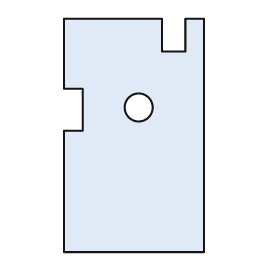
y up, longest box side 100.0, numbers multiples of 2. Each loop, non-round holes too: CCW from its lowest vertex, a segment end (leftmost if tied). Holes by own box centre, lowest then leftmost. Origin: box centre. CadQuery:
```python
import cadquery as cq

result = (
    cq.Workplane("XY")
    .moveTo(-30.0, -50.0)
    .lineTo(30.0, -50.0)
    .lineTo(30.0, 50.0)
    .lineTo(22.0, 50.0)
    .lineTo(22.0, 36.0)
    .lineTo(12.0, 36.0)
    .lineTo(12.0, 50.0)
    .lineTo(-30.0, 50.0)
    .lineTo(-30.0, 20.0)
    .lineTo(-22.0, 20.0)
    .lineTo(-22.0, 2.0)
    .lineTo(-30.0, 2.0)
    .close()
    .moveTo(2.0, 12.0)
    .circle(6.0)
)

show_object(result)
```